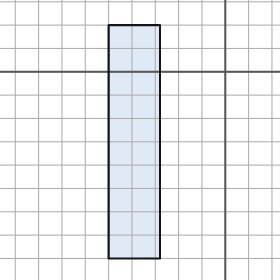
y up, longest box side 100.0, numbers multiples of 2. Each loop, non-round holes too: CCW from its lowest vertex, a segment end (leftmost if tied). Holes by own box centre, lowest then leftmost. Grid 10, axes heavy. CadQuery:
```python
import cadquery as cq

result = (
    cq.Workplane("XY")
    .moveTo(-50.0, -80.0)
    .lineTo(-28.0, -80.0)
    .lineTo(-28.0, 20.0)
    .lineTo(-50.0, 20.0)
    .close()
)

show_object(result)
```